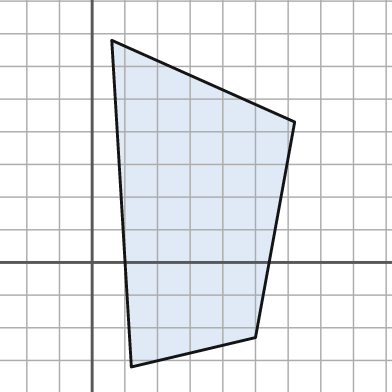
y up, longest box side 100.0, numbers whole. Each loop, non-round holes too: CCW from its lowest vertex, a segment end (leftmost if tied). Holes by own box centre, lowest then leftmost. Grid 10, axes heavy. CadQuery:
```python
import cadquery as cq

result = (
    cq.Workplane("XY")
    .moveTo(12.0, -32.0)
    .lineTo(50.0, -23.0)
    .lineTo(62.0, 43.0)
    .lineTo(6.0, 68.0)
    .close()
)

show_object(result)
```